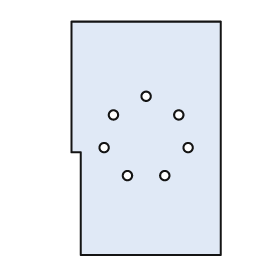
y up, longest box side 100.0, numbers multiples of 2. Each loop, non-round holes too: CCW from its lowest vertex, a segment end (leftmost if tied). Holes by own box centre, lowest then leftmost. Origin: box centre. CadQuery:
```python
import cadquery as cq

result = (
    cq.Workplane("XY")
    .moveTo(-28.0, -50.0)
    .lineTo(32.0, -50.0)
    .lineTo(32.0, 50.0)
    .lineTo(-32.0, 50.0)
    .lineTo(-32.0, -6.0)
    .lineTo(-28.0, -6.0)
    .close()
    .moveTo(-8.0, -16.0)
    .circle(2.0)
    .moveTo(8.0, -16.0)
    .circle(2.0)
    .moveTo(-18.0, -4.0)
    .circle(2.0)
    .moveTo(18.0, -4.0)
    .circle(2.0)
    .moveTo(-14.0, 10.0)
    .circle(2.0)
    .moveTo(14.0, 10.0)
    .circle(2.0)
    .moveTo(0.0, 18.0)
    .circle(2.0)
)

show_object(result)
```